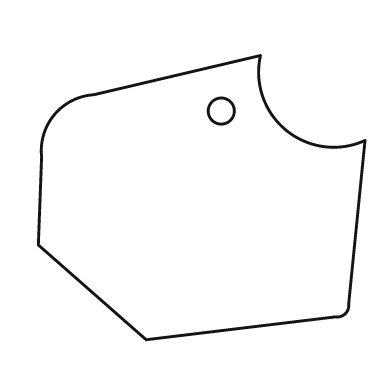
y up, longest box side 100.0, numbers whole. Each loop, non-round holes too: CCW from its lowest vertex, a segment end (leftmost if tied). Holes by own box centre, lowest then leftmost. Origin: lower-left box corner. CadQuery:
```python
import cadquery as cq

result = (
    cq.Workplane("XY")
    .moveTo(33.0, 0.0)
    .lineTo(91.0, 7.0)
    .threePointArc((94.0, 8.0), (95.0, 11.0))
    .lineTo(100.0, 61.0)
    .threePointArc((76.0, 64.0), (68.0, 87.0))
    .lineTo(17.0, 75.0)
    .threePointArc((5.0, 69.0), (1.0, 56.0))
    .lineTo(0.0, 29.0)
    .close()
    .moveTo(56.0, 70.0)
    .circle(4.0)
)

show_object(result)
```